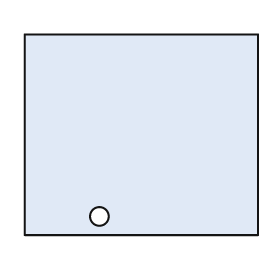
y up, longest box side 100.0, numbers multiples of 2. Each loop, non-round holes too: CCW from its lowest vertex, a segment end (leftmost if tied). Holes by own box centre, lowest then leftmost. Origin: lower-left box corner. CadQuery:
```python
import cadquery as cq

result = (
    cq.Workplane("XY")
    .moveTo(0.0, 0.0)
    .lineTo(100.0, 0.0)
    .lineTo(100.0, 86.0)
    .lineTo(0.0, 86.0)
    .close()
    .moveTo(32.0, 8.0)
    .circle(4.0)
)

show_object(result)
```